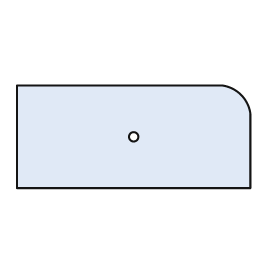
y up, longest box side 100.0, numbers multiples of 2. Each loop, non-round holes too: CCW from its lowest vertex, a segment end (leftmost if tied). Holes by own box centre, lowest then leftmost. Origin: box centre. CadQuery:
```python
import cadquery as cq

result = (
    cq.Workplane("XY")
    .moveTo(-50.0, -22.0)
    .lineTo(50.0, -22.0)
    .lineTo(50.0, 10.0)
    .threePointArc((46.0, 18.0), (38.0, 22.0))
    .lineTo(-50.0, 22.0)
    .close()
    .moveTo(0.0, 0.0)
    .circle(2.0)
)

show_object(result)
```